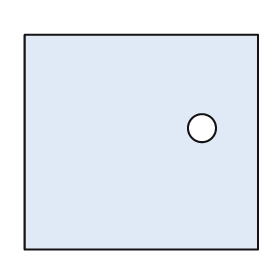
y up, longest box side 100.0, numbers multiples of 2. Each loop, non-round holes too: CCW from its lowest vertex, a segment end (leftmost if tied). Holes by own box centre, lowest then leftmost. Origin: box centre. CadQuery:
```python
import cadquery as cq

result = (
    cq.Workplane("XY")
    .moveTo(-50.0, -46.0)
    .lineTo(50.0, -46.0)
    .lineTo(50.0, 46.0)
    .lineTo(-50.0, 46.0)
    .close()
    .moveTo(26.0, 6.0)
    .circle(6.0)
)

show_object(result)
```